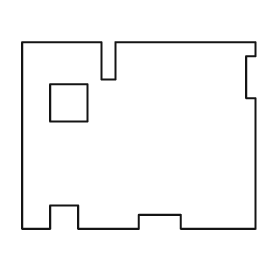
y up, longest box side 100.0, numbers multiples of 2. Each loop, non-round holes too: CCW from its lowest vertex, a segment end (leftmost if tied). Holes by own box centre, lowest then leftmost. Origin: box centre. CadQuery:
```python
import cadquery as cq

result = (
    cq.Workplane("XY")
    .moveTo(-50.0, -40.0)
    .lineTo(-38.0, -40.0)
    .lineTo(-38.0, -30.0)
    .lineTo(-26.0, -30.0)
    .lineTo(-26.0, -40.0)
    .lineTo(0.0, -40.0)
    .lineTo(0.0, -34.0)
    .lineTo(18.0, -34.0)
    .lineTo(18.0, -40.0)
    .lineTo(50.0, -40.0)
    .lineTo(50.0, 16.0)
    .lineTo(46.0, 16.0)
    .lineTo(46.0, 34.0)
    .lineTo(50.0, 34.0)
    .lineTo(50.0, 40.0)
    .lineTo(-10.0, 40.0)
    .lineTo(-10.0, 24.0)
    .lineTo(-16.0, 24.0)
    .lineTo(-16.0, 40.0)
    .lineTo(-50.0, 40.0)
    .close()
    .moveTo(-38.0, 6.0)
    .lineTo(-22.0, 6.0)
    .lineTo(-22.0, 22.0)
    .lineTo(-38.0, 22.0)
    .close()
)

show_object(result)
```